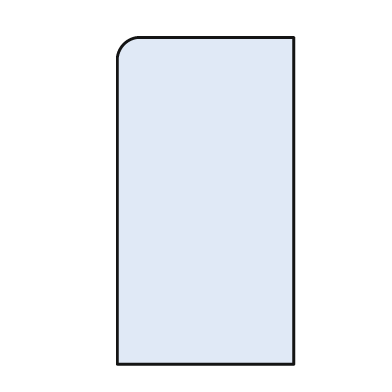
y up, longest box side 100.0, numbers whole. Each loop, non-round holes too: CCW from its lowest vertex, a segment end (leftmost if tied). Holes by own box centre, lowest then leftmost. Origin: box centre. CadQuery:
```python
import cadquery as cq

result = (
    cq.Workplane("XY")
    .moveTo(-27.0, -50.0)
    .lineTo(27.0, -50.0)
    .lineTo(27.0, 50.0)
    .lineTo(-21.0, 50.0)
    .threePointArc((-25.0, 48.0), (-27.0, 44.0))
    .close()
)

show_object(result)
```